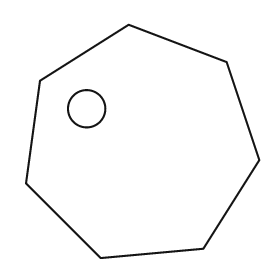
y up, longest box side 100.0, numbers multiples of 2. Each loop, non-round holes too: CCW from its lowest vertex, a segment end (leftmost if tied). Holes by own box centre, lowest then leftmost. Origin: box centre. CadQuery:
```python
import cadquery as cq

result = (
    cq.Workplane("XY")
    .moveTo(-18.0, -50.0)
    .lineTo(26.0, -46.0)
    .lineTo(50.0, -8.0)
    .lineTo(36.0, 34.0)
    .lineTo(-6.0, 50.0)
    .lineTo(-44.0, 26.0)
    .lineTo(-50.0, -18.0)
    .close()
    .moveTo(-24.0, 14.0)
    .circle(8.0)
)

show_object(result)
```